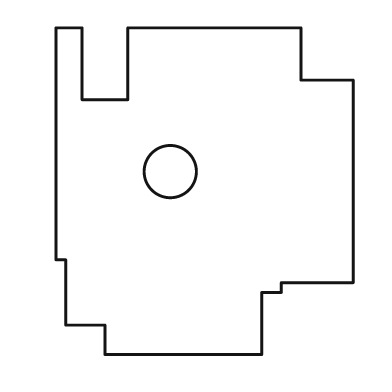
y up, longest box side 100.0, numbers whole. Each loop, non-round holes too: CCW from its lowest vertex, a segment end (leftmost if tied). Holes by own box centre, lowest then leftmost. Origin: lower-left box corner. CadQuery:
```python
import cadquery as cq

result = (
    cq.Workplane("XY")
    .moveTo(15.0, 0.0)
    .lineTo(63.0, 0.0)
    .lineTo(63.0, 19.0)
    .lineTo(69.0, 19.0)
    .lineTo(69.0, 22.0)
    .lineTo(91.0, 22.0)
    .lineTo(91.0, 84.0)
    .lineTo(75.0, 84.0)
    .lineTo(75.0, 100.0)
    .lineTo(22.0, 100.0)
    .lineTo(22.0, 78.0)
    .lineTo(8.0, 78.0)
    .lineTo(8.0, 100.0)
    .lineTo(0.0, 100.0)
    .lineTo(0.0, 29.0)
    .lineTo(3.0, 29.0)
    .lineTo(3.0, 9.0)
    .lineTo(15.0, 9.0)
    .close()
    .moveTo(35.0, 56.0)
    .circle(8.0)
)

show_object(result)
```